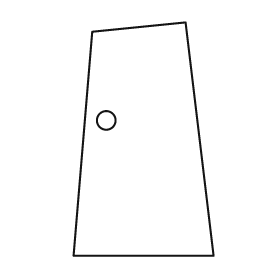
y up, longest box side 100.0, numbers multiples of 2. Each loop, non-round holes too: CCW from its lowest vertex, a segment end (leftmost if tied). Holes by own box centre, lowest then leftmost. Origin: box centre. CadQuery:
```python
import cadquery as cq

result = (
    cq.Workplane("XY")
    .moveTo(-30.0, -50.0)
    .lineTo(30.0, -50.0)
    .lineTo(18.0, 50.0)
    .lineTo(-22.0, 46.0)
    .close()
    .moveTo(-16.0, 8.0)
    .circle(4.0)
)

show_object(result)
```